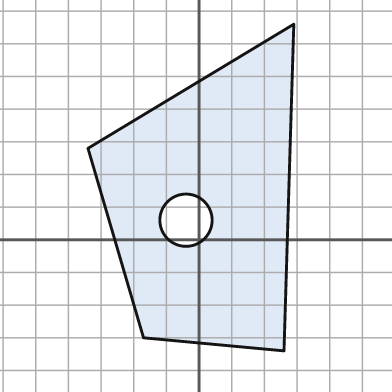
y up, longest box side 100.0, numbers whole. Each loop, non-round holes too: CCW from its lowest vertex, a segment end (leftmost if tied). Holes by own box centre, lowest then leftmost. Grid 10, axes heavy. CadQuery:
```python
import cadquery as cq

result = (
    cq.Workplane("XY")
    .moveTo(26.0, -34.0)
    .lineTo(29.0, 66.0)
    .lineTo(-34.0, 28.0)
    .lineTo(-17.0, -30.0)
    .close()
    .moveTo(-4.0, 6.0)
    .circle(8.0)
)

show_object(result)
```